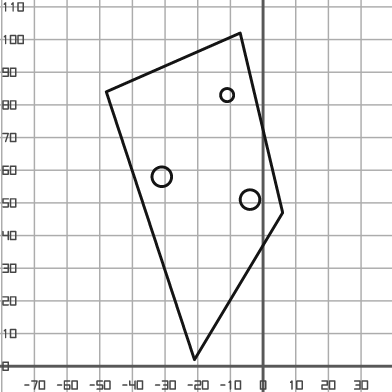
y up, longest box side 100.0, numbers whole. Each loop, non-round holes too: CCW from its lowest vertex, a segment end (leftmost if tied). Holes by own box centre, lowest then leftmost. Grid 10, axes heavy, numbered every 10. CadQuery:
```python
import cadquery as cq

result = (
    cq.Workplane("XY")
    .moveTo(-21.0, 2.0)
    .lineTo(6.0, 47.0)
    .lineTo(-7.0, 102.0)
    .lineTo(-48.0, 84.0)
    .close()
    .moveTo(-4.0, 51.0)
    .circle(3.0)
    .moveTo(-31.0, 58.0)
    .circle(3.0)
    .moveTo(-11.0, 83.0)
    .circle(2.0)
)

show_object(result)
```